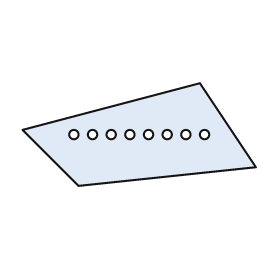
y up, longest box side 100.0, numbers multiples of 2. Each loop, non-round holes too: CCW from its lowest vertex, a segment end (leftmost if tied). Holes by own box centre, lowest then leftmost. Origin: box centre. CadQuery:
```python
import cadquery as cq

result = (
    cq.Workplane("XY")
    .moveTo(-26.0, -22.0)
    .lineTo(50.0, -14.0)
    .lineTo(26.0, 22.0)
    .lineTo(-50.0, 2.0)
    .close()
    .moveTo(-28.0, 0.0)
    .circle(2.0)
    .moveTo(-20.0, 0.0)
    .circle(2.0)
    .moveTo(-12.0, 0.0)
    .circle(2.0)
    .moveTo(-4.0, 0.0)
    .circle(2.0)
    .moveTo(4.0, 0.0)
    .circle(2.0)
    .moveTo(12.0, 0.0)
    .circle(2.0)
    .moveTo(20.0, 0.0)
    .circle(2.0)
    .moveTo(28.0, 0.0)
    .circle(2.0)
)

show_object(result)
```